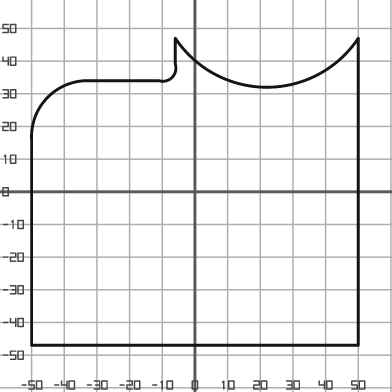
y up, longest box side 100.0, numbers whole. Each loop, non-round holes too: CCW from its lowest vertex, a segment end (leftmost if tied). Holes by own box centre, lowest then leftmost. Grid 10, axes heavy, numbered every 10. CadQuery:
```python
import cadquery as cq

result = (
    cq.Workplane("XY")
    .moveTo(-50.0, -47.0)
    .lineTo(50.0, -47.0)
    .lineTo(50.0, 47.0)
    .threePointArc((22.0, 32.0), (-6.0, 47.0))
    .lineTo(-6.0, 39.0)
    .threePointArc((-7.0, 35.0), (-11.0, 34.0))
    .lineTo(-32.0, 34.0)
    .threePointArc((-45.0, 29.0), (-50.0, 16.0))
    .close()
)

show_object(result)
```